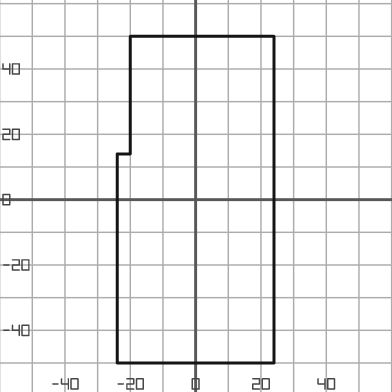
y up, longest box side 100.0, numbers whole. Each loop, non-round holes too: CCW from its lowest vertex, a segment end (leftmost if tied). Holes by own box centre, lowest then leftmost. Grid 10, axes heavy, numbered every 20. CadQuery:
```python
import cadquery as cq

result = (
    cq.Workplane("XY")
    .moveTo(-24.0, -50.0)
    .lineTo(24.0, -50.0)
    .lineTo(24.0, 50.0)
    .lineTo(-20.0, 50.0)
    .lineTo(-20.0, 14.0)
    .lineTo(-24.0, 14.0)
    .close()
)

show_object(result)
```